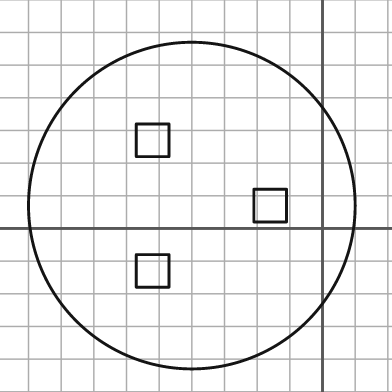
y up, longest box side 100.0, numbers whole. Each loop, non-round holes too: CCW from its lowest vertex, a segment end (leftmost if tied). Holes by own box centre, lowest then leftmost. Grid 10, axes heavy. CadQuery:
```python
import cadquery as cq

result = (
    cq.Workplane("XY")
    .moveTo(-40.0, 7.0)
    .circle(50.0)
    .moveTo(-57.0, -18.0)
    .lineTo(-47.0, -18.0)
    .lineTo(-47.0, -8.0)
    .lineTo(-57.0, -8.0)
    .close()
    .moveTo(-21.0, 2.0)
    .lineTo(-11.0, 2.0)
    .lineTo(-11.0, 12.0)
    .lineTo(-21.0, 12.0)
    .close()
    .moveTo(-57.0, 22.0)
    .lineTo(-47.0, 22.0)
    .lineTo(-47.0, 32.0)
    .lineTo(-57.0, 32.0)
    .close()
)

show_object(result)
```